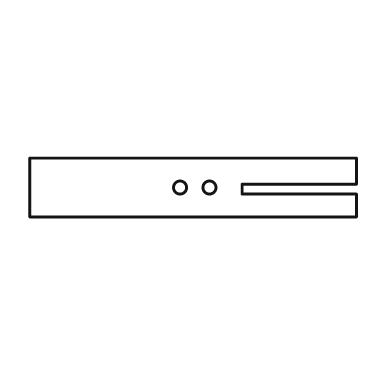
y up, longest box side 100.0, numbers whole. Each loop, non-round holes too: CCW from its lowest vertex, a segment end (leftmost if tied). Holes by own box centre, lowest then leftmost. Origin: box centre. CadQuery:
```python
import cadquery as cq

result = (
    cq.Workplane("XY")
    .moveTo(-50.0, -9.0)
    .lineTo(50.0, -9.0)
    .lineTo(50.0, -2.0)
    .lineTo(15.0, -2.0)
    .lineTo(15.0, 1.0)
    .lineTo(50.0, 1.0)
    .lineTo(50.0, 9.0)
    .lineTo(-50.0, 9.0)
    .close()
    .moveTo(-4.0, 0.0)
    .circle(2.0)
    .moveTo(5.0, 0.0)
    .circle(2.0)
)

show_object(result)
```